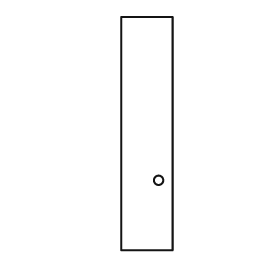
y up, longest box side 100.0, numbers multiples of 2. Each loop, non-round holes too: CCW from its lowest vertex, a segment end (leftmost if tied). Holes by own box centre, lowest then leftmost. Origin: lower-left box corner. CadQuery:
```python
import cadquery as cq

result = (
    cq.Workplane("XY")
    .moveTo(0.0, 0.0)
    .lineTo(22.0, 0.0)
    .lineTo(22.0, 100.0)
    .lineTo(0.0, 100.0)
    .close()
    .moveTo(16.0, 30.0)
    .circle(2.0)
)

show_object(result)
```